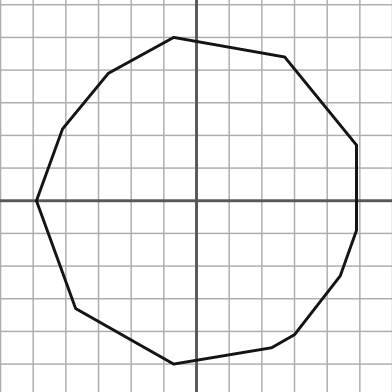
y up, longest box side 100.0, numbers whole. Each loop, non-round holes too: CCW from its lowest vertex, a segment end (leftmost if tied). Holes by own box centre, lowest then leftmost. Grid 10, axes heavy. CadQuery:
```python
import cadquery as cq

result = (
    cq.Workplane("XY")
    .moveTo(-7.0, -50.0)
    .lineTo(23.0, -45.0)
    .lineTo(30.0, -41.0)
    .lineTo(44.0, -23.0)
    .lineTo(49.0, -9.0)
    .lineTo(49.0, 17.0)
    .lineTo(27.0, 44.0)
    .lineTo(-7.0, 50.0)
    .lineTo(-27.0, 39.0)
    .lineTo(-41.0, 22.0)
    .lineTo(-49.0, 0.0)
    .lineTo(-37.0, -33.0)
    .close()
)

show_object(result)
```